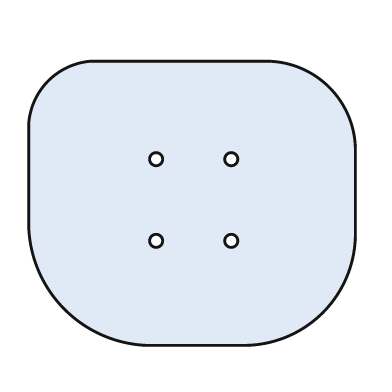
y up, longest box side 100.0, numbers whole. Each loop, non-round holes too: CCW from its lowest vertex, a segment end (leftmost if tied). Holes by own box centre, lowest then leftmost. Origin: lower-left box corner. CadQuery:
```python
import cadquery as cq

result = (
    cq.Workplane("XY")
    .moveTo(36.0, 0.0)
    .lineTo(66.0, 0.0)
    .threePointArc((90.0, 10.0), (100.0, 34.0))
    .lineTo(100.0, 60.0)
    .threePointArc((92.0, 79.0), (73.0, 87.0))
    .lineTo(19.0, 87.0)
    .threePointArc((6.0, 81.0), (0.0, 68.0))
    .lineTo(0.0, 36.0)
    .threePointArc((11.0, 11.0), (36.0, 0.0))
    .close()
    .moveTo(39.0, 32.0)
    .circle(2.0)
    .moveTo(62.0, 32.0)
    .circle(2.0)
    .moveTo(39.0, 57.0)
    .circle(2.0)
    .moveTo(62.0, 57.0)
    .circle(2.0)
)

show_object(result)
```